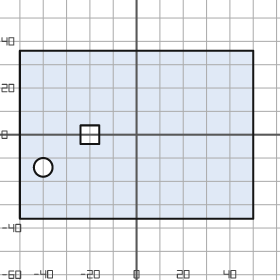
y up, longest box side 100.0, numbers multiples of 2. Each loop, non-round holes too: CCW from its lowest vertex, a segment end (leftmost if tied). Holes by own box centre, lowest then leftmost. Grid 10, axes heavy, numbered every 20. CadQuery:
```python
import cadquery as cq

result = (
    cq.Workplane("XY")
    .moveTo(-50.0, -36.0)
    .lineTo(50.0, -36.0)
    .lineTo(50.0, 36.0)
    .lineTo(-50.0, 36.0)
    .close()
    .moveTo(-40.0, -14.0)
    .circle(4.0)
    .moveTo(-24.0, -4.0)
    .lineTo(-16.0, -4.0)
    .lineTo(-16.0, 4.0)
    .lineTo(-24.0, 4.0)
    .close()
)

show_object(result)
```